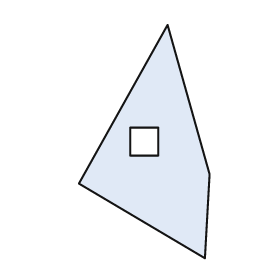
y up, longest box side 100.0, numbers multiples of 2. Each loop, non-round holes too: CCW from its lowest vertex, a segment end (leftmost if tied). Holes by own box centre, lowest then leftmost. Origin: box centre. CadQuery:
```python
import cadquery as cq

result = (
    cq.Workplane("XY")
    .moveTo(26.0, -50.0)
    .lineTo(28.0, -14.0)
    .lineTo(10.0, 50.0)
    .lineTo(-28.0, -18.0)
    .close()
    .moveTo(-6.0, -6.0)
    .lineTo(6.0, -6.0)
    .lineTo(6.0, 6.0)
    .lineTo(-6.0, 6.0)
    .close()
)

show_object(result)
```